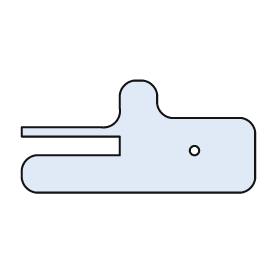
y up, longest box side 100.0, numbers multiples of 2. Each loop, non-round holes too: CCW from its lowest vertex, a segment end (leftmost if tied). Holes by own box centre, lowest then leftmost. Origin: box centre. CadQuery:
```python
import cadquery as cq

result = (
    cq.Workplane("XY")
    .moveTo(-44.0, -24.0)
    .lineTo(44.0, -24.0)
    .threePointArc((48.0, -22.0), (50.0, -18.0))
    .lineTo(50.0, 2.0)
    .threePointArc((48.0, 6.0), (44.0, 8.0))
    .lineTo(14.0, 8.0)
    .threePointArc((10.0, 10.0), (8.0, 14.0))
    .lineTo(8.0, 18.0)
    .threePointArc((6.0, 22.0), (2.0, 24.0))
    .lineTo(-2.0, 24.0)
    .threePointArc((-6.0, 22.0), (-8.0, 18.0))
    .lineTo(-8.0, 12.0)
    .threePointArc((-10.0, 6.0), (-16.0, 4.0))
    .lineTo(-50.0, 4.0)
    .lineTo(-50.0, 0.0)
    .lineTo(-8.0, 0.0)
    .lineTo(-8.0, -8.0)
    .lineTo(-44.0, -8.0)
    .threePointArc((-48.0, -10.0), (-50.0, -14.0))
    .lineTo(-50.0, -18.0)
    .threePointArc((-48.0, -22.0), (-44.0, -24.0))
    .close()
    .moveTo(24.0, -6.0)
    .circle(2.0)
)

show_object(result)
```